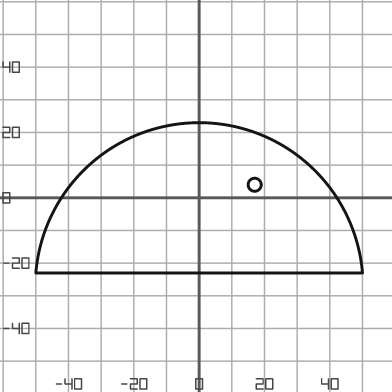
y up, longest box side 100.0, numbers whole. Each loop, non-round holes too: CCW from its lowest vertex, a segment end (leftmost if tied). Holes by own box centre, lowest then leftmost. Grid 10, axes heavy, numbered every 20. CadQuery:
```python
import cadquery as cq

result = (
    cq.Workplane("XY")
    .moveTo(-50.0, -23.0)
    .lineTo(50.0, -23.0)
    .threePointArc((0.0, 23.0), (-50.0, -23.0))
    .close()
    .moveTo(17.0, 4.0)
    .circle(2.0)
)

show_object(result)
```